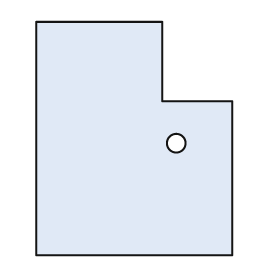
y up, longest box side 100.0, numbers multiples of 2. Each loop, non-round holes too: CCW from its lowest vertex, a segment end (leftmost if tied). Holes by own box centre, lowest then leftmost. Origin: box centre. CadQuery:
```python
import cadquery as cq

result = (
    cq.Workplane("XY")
    .moveTo(-42.0, -50.0)
    .lineTo(42.0, -50.0)
    .lineTo(42.0, 16.0)
    .lineTo(12.0, 16.0)
    .lineTo(12.0, 50.0)
    .lineTo(-42.0, 50.0)
    .close()
    .moveTo(18.0, -2.0)
    .circle(4.0)
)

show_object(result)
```